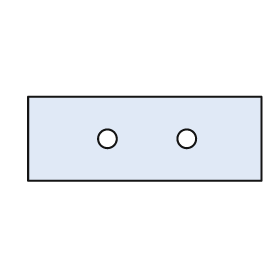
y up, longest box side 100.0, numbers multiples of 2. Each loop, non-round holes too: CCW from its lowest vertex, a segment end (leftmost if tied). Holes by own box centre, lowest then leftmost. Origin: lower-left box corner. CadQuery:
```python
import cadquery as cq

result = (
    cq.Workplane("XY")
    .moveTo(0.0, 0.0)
    .lineTo(100.0, 0.0)
    .lineTo(100.0, 36.0)
    .lineTo(0.0, 36.0)
    .close()
    .moveTo(34.0, 18.0)
    .circle(4.0)
    .moveTo(68.0, 18.0)
    .circle(4.0)
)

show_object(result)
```